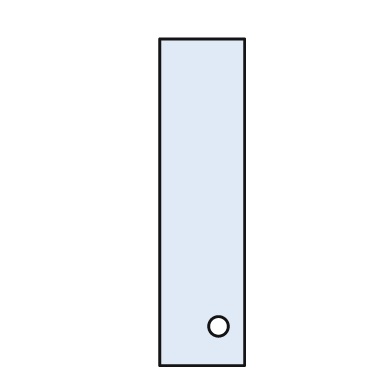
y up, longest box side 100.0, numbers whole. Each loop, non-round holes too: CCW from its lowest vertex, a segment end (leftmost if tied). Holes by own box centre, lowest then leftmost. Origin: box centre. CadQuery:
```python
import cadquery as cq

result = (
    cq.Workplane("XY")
    .moveTo(-13.0, -50.0)
    .lineTo(13.0, -50.0)
    .lineTo(13.0, 50.0)
    .lineTo(-13.0, 50.0)
    .close()
    .moveTo(5.0, -38.0)
    .circle(3.0)
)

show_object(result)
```